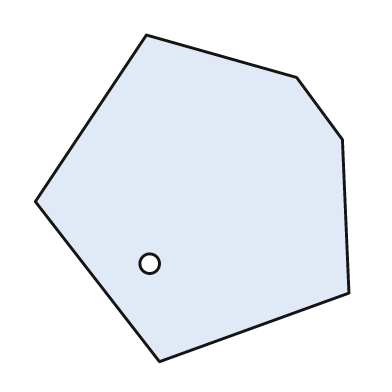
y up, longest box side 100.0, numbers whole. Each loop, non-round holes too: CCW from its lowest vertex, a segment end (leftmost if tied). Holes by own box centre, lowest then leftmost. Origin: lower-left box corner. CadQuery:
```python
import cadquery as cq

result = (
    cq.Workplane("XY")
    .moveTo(38.0, 0.0)
    .lineTo(96.0, 21.0)
    .lineTo(94.0, 68.0)
    .lineTo(80.0, 87.0)
    .lineTo(34.0, 100.0)
    .lineTo(0.0, 49.0)
    .close()
    .moveTo(35.0, 30.0)
    .circle(3.0)
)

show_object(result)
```